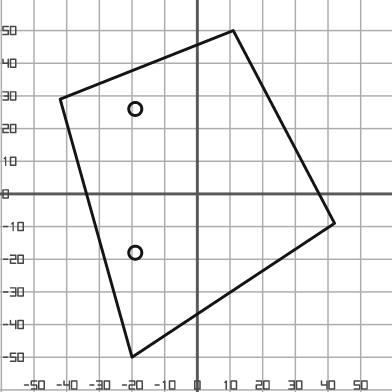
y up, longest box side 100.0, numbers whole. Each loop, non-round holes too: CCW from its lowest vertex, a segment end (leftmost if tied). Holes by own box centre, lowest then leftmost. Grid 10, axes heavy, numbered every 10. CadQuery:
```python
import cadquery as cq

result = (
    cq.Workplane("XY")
    .moveTo(-20.0, -50.0)
    .lineTo(42.0, -9.0)
    .lineTo(11.0, 50.0)
    .lineTo(-42.0, 29.0)
    .close()
    .moveTo(-19.0, -18.0)
    .circle(2.0)
    .moveTo(-19.0, 26.0)
    .circle(2.0)
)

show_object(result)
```